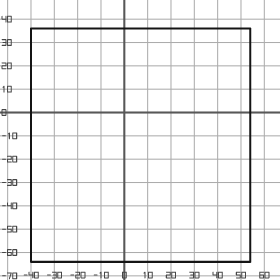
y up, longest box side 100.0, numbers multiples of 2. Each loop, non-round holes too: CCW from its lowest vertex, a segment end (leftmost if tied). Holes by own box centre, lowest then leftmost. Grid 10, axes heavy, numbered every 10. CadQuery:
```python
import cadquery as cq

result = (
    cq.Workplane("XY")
    .moveTo(-40.0, -64.0)
    .lineTo(54.0, -64.0)
    .lineTo(54.0, 36.0)
    .lineTo(-40.0, 36.0)
    .close()
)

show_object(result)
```